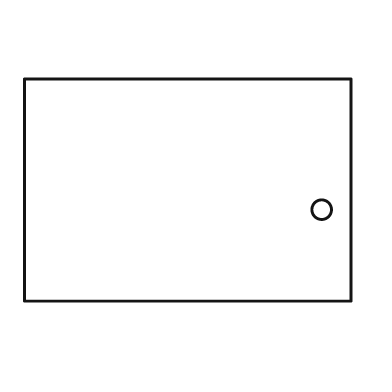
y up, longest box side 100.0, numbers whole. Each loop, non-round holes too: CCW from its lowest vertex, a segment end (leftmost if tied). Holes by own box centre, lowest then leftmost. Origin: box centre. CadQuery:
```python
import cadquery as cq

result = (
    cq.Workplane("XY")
    .moveTo(-50.0, -34.0)
    .lineTo(50.0, -34.0)
    .lineTo(50.0, 34.0)
    .lineTo(-50.0, 34.0)
    .close()
    .moveTo(41.0, -6.0)
    .circle(3.0)
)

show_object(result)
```